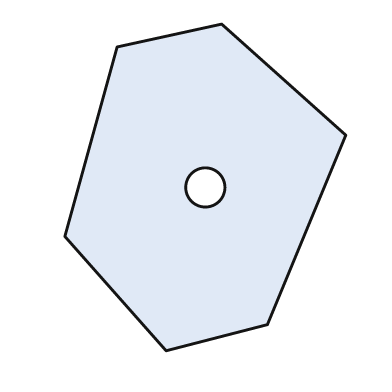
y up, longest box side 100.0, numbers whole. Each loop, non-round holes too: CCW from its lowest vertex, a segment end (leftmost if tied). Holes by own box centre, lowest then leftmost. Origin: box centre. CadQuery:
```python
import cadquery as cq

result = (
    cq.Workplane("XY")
    .moveTo(-12.0, -50.0)
    .lineTo(19.0, -42.0)
    .lineTo(43.0, 16.0)
    .lineTo(5.0, 50.0)
    .lineTo(-27.0, 43.0)
    .lineTo(-43.0, -15.0)
    .close()
    .moveTo(0.0, 0.0)
    .circle(6.0)
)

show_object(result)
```